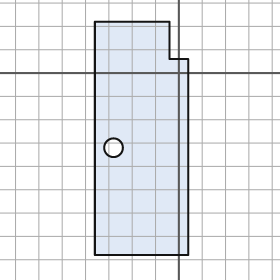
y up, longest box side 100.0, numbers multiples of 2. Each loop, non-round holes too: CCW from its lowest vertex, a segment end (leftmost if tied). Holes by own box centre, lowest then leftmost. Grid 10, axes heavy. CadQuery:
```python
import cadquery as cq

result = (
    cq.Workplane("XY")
    .moveTo(-36.0, -78.0)
    .lineTo(4.0, -78.0)
    .lineTo(4.0, 6.0)
    .lineTo(-4.0, 6.0)
    .lineTo(-4.0, 22.0)
    .lineTo(-36.0, 22.0)
    .close()
    .moveTo(-28.0, -32.0)
    .circle(4.0)
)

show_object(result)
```